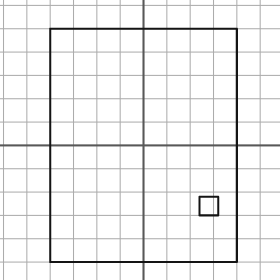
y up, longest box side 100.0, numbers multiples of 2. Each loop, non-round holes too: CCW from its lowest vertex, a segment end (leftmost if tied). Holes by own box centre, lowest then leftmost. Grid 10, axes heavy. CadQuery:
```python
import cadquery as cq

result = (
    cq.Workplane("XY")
    .moveTo(-40.0, -50.0)
    .lineTo(40.0, -50.0)
    .lineTo(40.0, 50.0)
    .lineTo(-40.0, 50.0)
    .close()
    .moveTo(24.0, -30.0)
    .lineTo(32.0, -30.0)
    .lineTo(32.0, -22.0)
    .lineTo(24.0, -22.0)
    .close()
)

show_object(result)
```